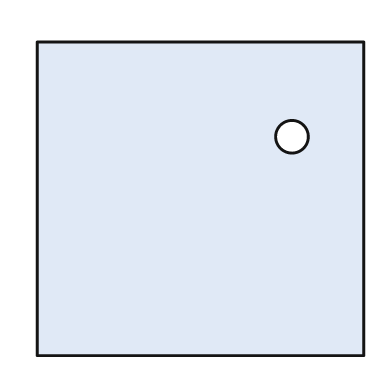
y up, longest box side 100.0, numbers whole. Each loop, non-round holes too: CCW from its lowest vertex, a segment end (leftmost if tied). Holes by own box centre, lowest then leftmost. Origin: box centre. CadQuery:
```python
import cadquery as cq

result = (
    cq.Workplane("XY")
    .moveTo(-50.0, -48.0)
    .lineTo(50.0, -48.0)
    .lineTo(50.0, 48.0)
    .lineTo(-50.0, 48.0)
    .close()
    .moveTo(28.0, 19.0)
    .circle(5.0)
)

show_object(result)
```